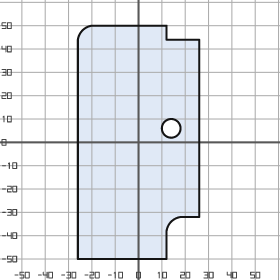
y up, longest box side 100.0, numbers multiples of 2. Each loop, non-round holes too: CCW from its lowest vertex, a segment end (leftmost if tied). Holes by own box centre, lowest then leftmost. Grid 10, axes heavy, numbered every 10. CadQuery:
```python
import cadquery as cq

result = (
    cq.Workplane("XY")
    .moveTo(-26.0, -50.0)
    .lineTo(12.0, -50.0)
    .lineTo(12.0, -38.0)
    .threePointArc((14.0, -34.0), (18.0, -32.0))
    .lineTo(26.0, -32.0)
    .lineTo(26.0, 44.0)
    .lineTo(12.0, 44.0)
    .lineTo(12.0, 50.0)
    .lineTo(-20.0, 50.0)
    .threePointArc((-24.0, 48.0), (-26.0, 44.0))
    .close()
    .moveTo(14.0, 6.0)
    .circle(4.0)
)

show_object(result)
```